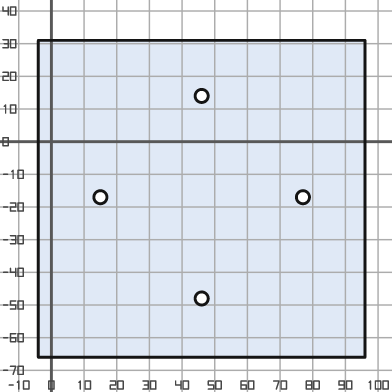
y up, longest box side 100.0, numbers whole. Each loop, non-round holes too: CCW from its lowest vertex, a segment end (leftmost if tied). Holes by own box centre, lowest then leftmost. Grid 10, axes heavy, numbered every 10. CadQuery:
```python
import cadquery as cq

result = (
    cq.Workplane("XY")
    .moveTo(-4.0, -66.0)
    .lineTo(96.0, -66.0)
    .lineTo(96.0, 31.0)
    .lineTo(-4.0, 31.0)
    .close()
    .moveTo(46.0, -48.0)
    .circle(2.0)
    .moveTo(15.0, -17.0)
    .circle(2.0)
    .moveTo(77.0, -17.0)
    .circle(2.0)
    .moveTo(46.0, 14.0)
    .circle(2.0)
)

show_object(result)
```